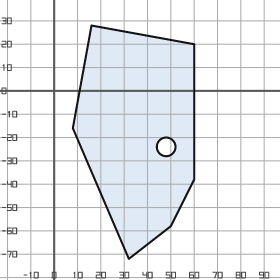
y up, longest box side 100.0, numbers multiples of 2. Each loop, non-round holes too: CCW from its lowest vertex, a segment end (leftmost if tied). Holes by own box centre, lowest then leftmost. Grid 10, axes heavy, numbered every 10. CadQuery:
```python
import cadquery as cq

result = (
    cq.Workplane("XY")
    .moveTo(32.0, -72.0)
    .lineTo(50.0, -58.0)
    .lineTo(60.0, -38.0)
    .lineTo(60.0, 20.0)
    .lineTo(16.0, 28.0)
    .lineTo(8.0, -16.0)
    .close()
    .moveTo(48.0, -24.0)
    .circle(4.0)
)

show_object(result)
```